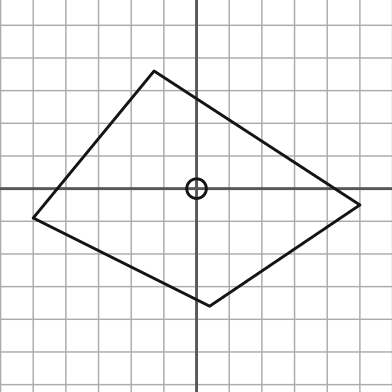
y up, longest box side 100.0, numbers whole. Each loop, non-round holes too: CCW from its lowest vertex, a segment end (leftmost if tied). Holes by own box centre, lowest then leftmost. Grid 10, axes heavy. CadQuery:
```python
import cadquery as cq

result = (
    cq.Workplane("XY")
    .moveTo(4.0, -36.0)
    .lineTo(50.0, -5.0)
    .lineTo(-13.0, 36.0)
    .lineTo(-50.0, -9.0)
    .close()
    .moveTo(0.0, 0.0)
    .circle(3.0)
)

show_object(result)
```